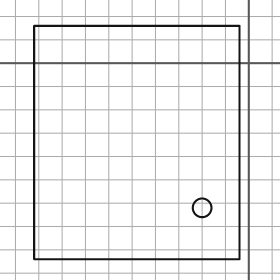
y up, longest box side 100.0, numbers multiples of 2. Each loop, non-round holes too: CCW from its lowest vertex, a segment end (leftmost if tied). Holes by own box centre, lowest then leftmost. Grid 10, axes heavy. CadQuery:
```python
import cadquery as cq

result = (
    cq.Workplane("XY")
    .moveTo(-92.0, -84.0)
    .lineTo(-4.0, -84.0)
    .lineTo(-4.0, 16.0)
    .lineTo(-92.0, 16.0)
    .close()
    .moveTo(-20.0, -62.0)
    .circle(4.0)
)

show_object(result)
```